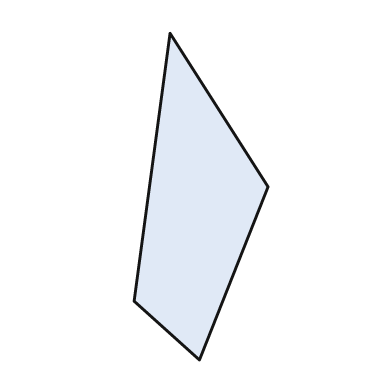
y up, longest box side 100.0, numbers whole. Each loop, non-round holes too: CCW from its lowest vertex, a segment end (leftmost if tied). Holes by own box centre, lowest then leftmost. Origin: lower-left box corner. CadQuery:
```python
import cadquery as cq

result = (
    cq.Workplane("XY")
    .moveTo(20.0, 0.0)
    .lineTo(41.0, 53.0)
    .lineTo(11.0, 100.0)
    .lineTo(0.0, 18.0)
    .close()
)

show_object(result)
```